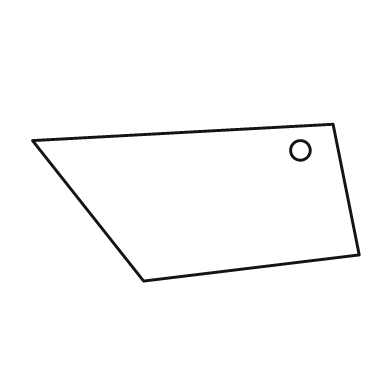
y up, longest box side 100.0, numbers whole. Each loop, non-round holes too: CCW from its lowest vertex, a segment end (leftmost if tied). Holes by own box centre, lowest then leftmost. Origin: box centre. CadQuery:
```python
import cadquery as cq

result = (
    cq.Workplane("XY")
    .moveTo(-16.0, -24.0)
    .lineTo(50.0, -16.0)
    .lineTo(42.0, 24.0)
    .lineTo(-50.0, 19.0)
    .close()
    .moveTo(32.0, 16.0)
    .circle(3.0)
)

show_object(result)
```